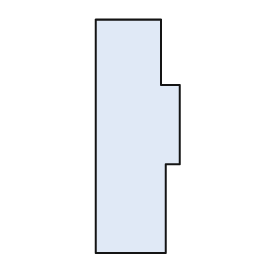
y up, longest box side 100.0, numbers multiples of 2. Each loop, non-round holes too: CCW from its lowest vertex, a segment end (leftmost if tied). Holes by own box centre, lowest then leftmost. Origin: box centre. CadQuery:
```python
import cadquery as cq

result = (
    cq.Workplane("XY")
    .moveTo(-18.0, -50.0)
    .lineTo(12.0, -50.0)
    .lineTo(12.0, -12.0)
    .lineTo(18.0, -12.0)
    .lineTo(18.0, 22.0)
    .lineTo(10.0, 22.0)
    .lineTo(10.0, 50.0)
    .lineTo(-18.0, 50.0)
    .close()
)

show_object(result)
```